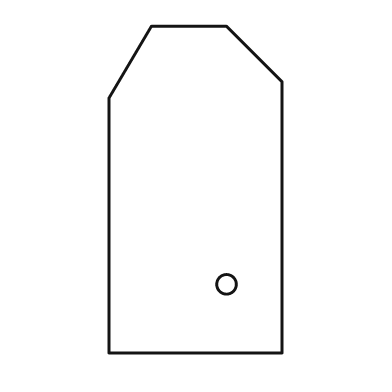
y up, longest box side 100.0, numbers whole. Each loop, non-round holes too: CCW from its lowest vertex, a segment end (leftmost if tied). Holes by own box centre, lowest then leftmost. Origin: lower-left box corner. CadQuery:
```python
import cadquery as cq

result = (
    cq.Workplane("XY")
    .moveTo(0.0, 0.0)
    .lineTo(53.0, 0.0)
    .lineTo(53.0, 83.0)
    .lineTo(36.0, 100.0)
    .lineTo(13.0, 100.0)
    .lineTo(0.0, 78.0)
    .close()
    .moveTo(36.0, 21.0)
    .circle(3.0)
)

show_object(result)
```